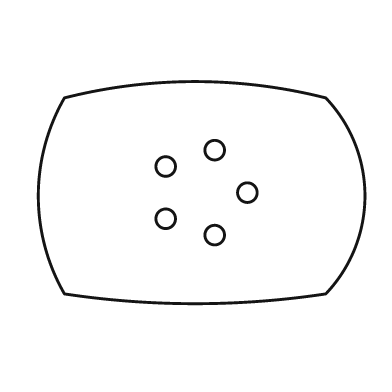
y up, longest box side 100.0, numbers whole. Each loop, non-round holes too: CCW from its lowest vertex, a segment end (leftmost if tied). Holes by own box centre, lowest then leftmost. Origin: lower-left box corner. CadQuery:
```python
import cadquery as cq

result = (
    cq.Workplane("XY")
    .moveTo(8.0, 3.0)
    .threePointArc((48.0, 0.0), (88.0, 3.0))
    .threePointArc((100.0, 33.0), (88.0, 63.0))
    .threePointArc((48.0, 68.0), (8.0, 63.0))
    .threePointArc((0.0, 33.0), (8.0, 3.0))
    .close()
    .moveTo(54.0, 21.0)
    .circle(3.0)
    .moveTo(39.0, 26.0)
    .circle(3.0)
    .moveTo(64.0, 34.0)
    .circle(3.0)
    .moveTo(39.0, 42.0)
    .circle(3.0)
    .moveTo(54.0, 47.0)
    .circle(3.0)
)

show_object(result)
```